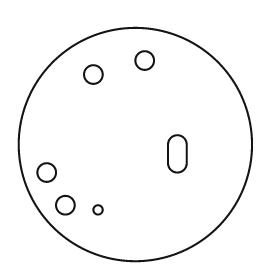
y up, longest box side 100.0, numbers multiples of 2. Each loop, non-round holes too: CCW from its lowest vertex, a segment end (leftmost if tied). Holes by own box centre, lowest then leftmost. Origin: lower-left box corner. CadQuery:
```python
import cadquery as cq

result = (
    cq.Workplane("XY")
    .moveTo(50.0, 50.0)
    .circle(50.0)
    .moveTo(34.0, 22.0)
    .circle(2.0)
    .moveTo(20.0, 24.0)
    .circle(4.0)
    .moveTo(12.0, 38.0)
    .circle(4.0)
    .moveTo(64.0, 42.0)
    .threePointArc((68.0, 38.0), (72.0, 42.0))
    .lineTo(72.0, 50.0)
    .threePointArc((68.0, 54.0), (64.0, 50.0))
    .close()
    .moveTo(32.0, 80.0)
    .circle(4.0)
    .moveTo(54.0, 86.0)
    .circle(4.0)
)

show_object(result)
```